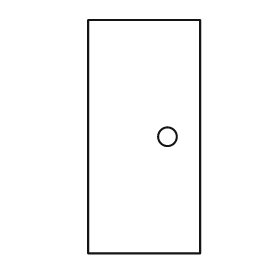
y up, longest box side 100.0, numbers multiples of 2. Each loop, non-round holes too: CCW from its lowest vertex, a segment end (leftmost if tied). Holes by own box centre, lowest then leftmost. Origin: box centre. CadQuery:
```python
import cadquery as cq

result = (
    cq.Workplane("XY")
    .moveTo(-24.0, -50.0)
    .lineTo(24.0, -50.0)
    .lineTo(24.0, 50.0)
    .lineTo(-24.0, 50.0)
    .close()
    .moveTo(10.0, 0.0)
    .circle(4.0)
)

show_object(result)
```